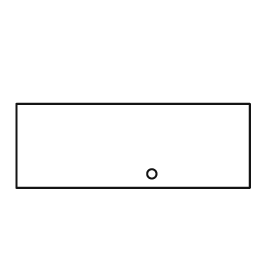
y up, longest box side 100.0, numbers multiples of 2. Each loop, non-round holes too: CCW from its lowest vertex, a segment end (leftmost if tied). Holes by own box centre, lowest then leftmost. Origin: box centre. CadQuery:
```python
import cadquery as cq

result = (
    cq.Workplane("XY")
    .moveTo(-50.0, -18.0)
    .lineTo(50.0, -18.0)
    .lineTo(50.0, 18.0)
    .lineTo(-50.0, 18.0)
    .close()
    .moveTo(8.0, -12.0)
    .circle(2.0)
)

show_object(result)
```